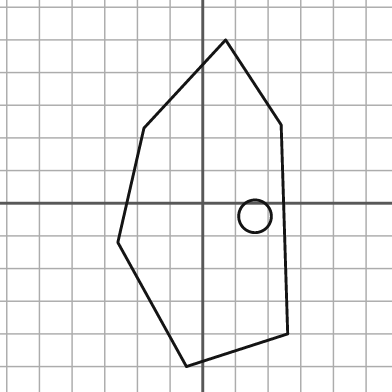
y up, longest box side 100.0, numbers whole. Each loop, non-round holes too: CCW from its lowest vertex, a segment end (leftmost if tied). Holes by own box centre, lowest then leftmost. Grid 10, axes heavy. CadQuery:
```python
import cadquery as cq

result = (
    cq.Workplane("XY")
    .moveTo(-5.0, -50.0)
    .lineTo(26.0, -40.0)
    .lineTo(24.0, 24.0)
    .lineTo(7.0, 50.0)
    .lineTo(-18.0, 23.0)
    .lineTo(-26.0, -12.0)
    .close()
    .moveTo(16.0, -4.0)
    .circle(5.0)
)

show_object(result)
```